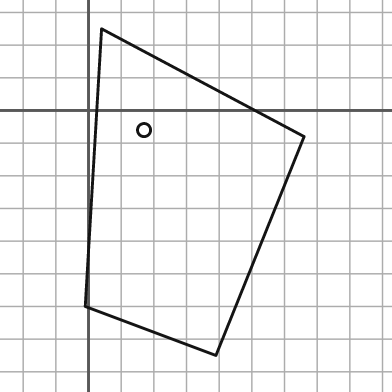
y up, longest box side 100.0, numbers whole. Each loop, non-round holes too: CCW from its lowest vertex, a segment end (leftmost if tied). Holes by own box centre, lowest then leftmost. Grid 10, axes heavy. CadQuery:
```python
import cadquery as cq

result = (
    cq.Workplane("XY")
    .moveTo(39.0, -75.0)
    .lineTo(66.0, -8.0)
    .lineTo(4.0, 25.0)
    .lineTo(-1.0, -60.0)
    .close()
    .moveTo(17.0, -6.0)
    .circle(2.0)
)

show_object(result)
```